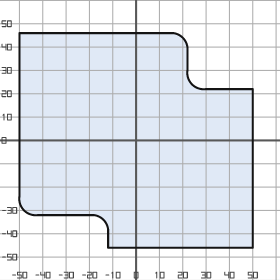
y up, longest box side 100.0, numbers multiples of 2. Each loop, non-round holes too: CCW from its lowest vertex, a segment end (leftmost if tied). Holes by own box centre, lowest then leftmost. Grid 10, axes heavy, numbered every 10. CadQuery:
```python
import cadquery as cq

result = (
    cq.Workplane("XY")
    .moveTo(-12.0, -46.0)
    .lineTo(50.0, -46.0)
    .lineTo(50.0, 22.0)
    .lineTo(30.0, 22.0)
    .threePointArc((24.0, 24.0), (22.0, 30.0))
    .lineTo(22.0, 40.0)
    .threePointArc((20.0, 44.0), (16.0, 46.0))
    .lineTo(-50.0, 46.0)
    .lineTo(-50.0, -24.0)
    .threePointArc((-48.0, -30.0), (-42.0, -32.0))
    .lineTo(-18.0, -32.0)
    .threePointArc((-14.0, -34.0), (-12.0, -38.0))
    .close()
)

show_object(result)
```